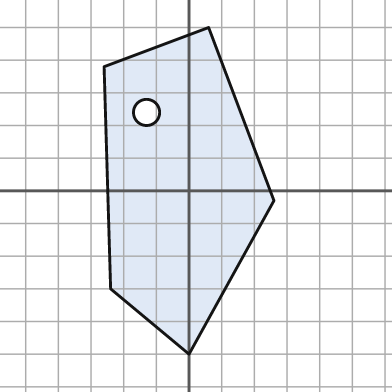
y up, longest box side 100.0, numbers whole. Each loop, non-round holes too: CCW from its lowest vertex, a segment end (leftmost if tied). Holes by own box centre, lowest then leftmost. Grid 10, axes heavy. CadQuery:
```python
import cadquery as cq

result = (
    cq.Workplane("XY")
    .moveTo(0.0, -50.0)
    .lineTo(26.0, -3.0)
    .lineTo(6.0, 50.0)
    .lineTo(-26.0, 38.0)
    .lineTo(-24.0, -30.0)
    .close()
    .moveTo(-13.0, 24.0)
    .circle(4.0)
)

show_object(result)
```